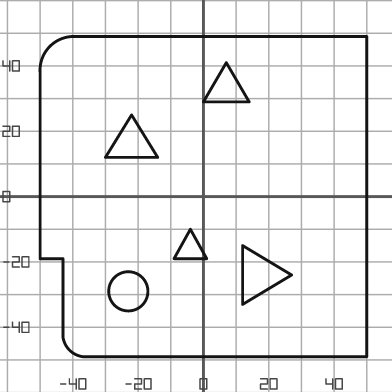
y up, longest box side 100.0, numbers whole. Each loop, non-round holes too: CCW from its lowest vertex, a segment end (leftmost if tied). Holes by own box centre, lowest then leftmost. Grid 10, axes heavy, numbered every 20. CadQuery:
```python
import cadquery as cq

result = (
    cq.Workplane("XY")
    .moveTo(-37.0, -49.0)
    .lineTo(50.0, -49.0)
    .lineTo(50.0, 49.0)
    .lineTo(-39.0, 49.0)
    .threePointArc((-47.0, 46.0), (-50.0, 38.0))
    .lineTo(-50.0, -19.0)
    .lineTo(-43.0, -19.0)
    .lineTo(-43.0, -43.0)
    .threePointArc((-41.0, -47.0), (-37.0, -49.0))
    .close()
    .moveTo(-23.0, -29.0)
    .circle(6.0)
    .moveTo(12.0, -33.0)
    .lineTo(27.0, -24.0)
    .lineTo(12.0, -15.0)
    .close()
    .moveTo(-9.0, -19.0)
    .lineTo(1.0, -19.0)
    .lineTo(-4.0, -10.0)
    .close()
    .moveTo(-30.0, 12.0)
    .lineTo(-14.0, 12.0)
    .lineTo(-22.0, 25.0)
    .close()
    .moveTo(0.0, 29.0)
    .lineTo(14.0, 29.0)
    .lineTo(7.0, 41.0)
    .close()
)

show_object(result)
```